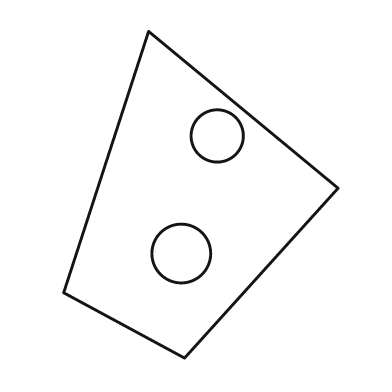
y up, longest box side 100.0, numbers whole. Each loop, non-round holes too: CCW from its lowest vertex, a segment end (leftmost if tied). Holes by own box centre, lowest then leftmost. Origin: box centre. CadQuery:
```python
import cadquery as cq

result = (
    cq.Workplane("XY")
    .moveTo(-5.0, -50.0)
    .lineTo(42.0, 2.0)
    .lineTo(-16.0, 50.0)
    .lineTo(-42.0, -30.0)
    .close()
    .moveTo(-6.0, -18.0)
    .circle(9.0)
    .moveTo(5.0, 18.0)
    .circle(8.0)
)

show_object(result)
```